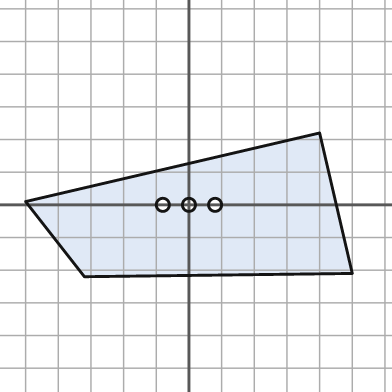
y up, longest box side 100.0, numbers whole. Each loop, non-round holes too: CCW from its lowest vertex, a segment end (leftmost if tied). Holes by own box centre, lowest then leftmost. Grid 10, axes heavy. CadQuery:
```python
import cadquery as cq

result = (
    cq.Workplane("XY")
    .moveTo(-32.0, -22.0)
    .lineTo(50.0, -21.0)
    .lineTo(40.0, 22.0)
    .lineTo(-50.0, 1.0)
    .close()
    .moveTo(-8.0, 0.0)
    .circle(2.0)
    .moveTo(0.0, 0.0)
    .circle(2.0)
    .moveTo(8.0, 0.0)
    .circle(2.0)
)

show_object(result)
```